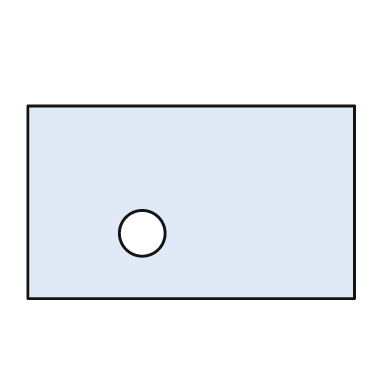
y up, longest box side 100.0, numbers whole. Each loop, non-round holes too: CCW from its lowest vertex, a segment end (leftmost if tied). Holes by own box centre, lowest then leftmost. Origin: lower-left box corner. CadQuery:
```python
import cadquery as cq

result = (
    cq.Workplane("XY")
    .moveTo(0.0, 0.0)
    .lineTo(100.0, 0.0)
    .lineTo(100.0, 59.0)
    .lineTo(0.0, 59.0)
    .close()
    .moveTo(35.0, 20.0)
    .circle(7.0)
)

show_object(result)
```